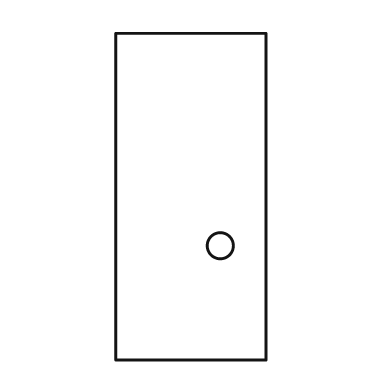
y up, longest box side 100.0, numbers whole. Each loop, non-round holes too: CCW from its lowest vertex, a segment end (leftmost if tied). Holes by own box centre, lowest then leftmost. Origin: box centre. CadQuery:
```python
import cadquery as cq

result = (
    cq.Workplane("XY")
    .moveTo(-23.0, -50.0)
    .lineTo(23.0, -50.0)
    .lineTo(23.0, 50.0)
    .lineTo(-23.0, 50.0)
    .close()
    .moveTo(9.0, -15.0)
    .circle(4.0)
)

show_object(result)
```